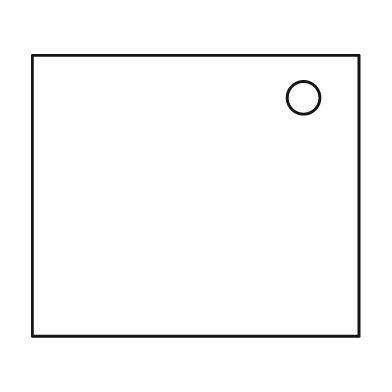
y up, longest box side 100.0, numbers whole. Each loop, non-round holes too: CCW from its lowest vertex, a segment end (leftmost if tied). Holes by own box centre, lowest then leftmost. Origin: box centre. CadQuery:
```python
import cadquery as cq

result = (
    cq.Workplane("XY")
    .moveTo(-50.0, -43.0)
    .lineTo(50.0, -43.0)
    .lineTo(50.0, 43.0)
    .lineTo(-50.0, 43.0)
    .close()
    .moveTo(33.0, 30.0)
    .circle(5.0)
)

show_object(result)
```